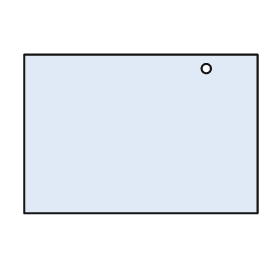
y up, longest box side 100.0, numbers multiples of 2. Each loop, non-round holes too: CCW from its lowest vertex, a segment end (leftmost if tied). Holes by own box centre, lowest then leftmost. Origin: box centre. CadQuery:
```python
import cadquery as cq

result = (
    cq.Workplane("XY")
    .moveTo(-50.0, -34.0)
    .lineTo(50.0, -34.0)
    .lineTo(50.0, 34.0)
    .lineTo(-50.0, 34.0)
    .close()
    .moveTo(28.0, 28.0)
    .circle(2.0)
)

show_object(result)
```